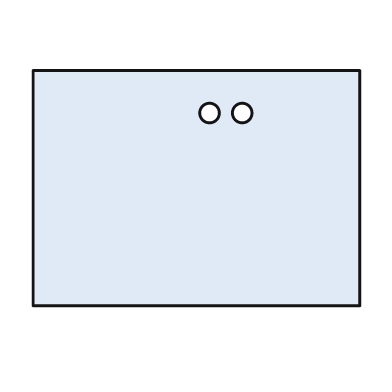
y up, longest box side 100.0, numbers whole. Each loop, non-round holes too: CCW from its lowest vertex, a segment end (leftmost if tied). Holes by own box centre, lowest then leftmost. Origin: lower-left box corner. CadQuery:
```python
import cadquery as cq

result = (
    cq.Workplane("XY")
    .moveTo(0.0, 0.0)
    .lineTo(100.0, 0.0)
    .lineTo(100.0, 72.0)
    .lineTo(0.0, 72.0)
    .close()
    .moveTo(54.0, 59.0)
    .circle(3.0)
    .moveTo(64.0, 59.0)
    .circle(3.0)
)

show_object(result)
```